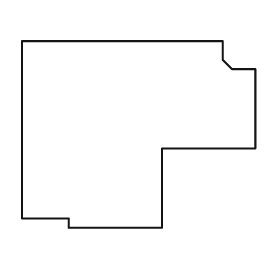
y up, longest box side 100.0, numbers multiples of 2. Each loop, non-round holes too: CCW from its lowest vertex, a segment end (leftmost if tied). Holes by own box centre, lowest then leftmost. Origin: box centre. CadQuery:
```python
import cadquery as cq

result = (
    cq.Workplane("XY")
    .moveTo(-30.0, -40.0)
    .lineTo(10.0, -40.0)
    .lineTo(10.0, -6.0)
    .lineTo(50.0, -6.0)
    .lineTo(50.0, 28.0)
    .lineTo(40.0, 28.0)
    .lineTo(36.0, 32.0)
    .lineTo(36.0, 40.0)
    .lineTo(-50.0, 40.0)
    .lineTo(-50.0, -36.0)
    .lineTo(-30.0, -36.0)
    .close()
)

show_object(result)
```